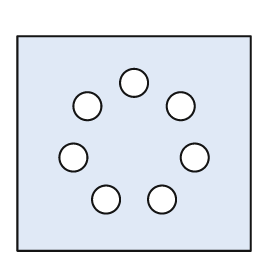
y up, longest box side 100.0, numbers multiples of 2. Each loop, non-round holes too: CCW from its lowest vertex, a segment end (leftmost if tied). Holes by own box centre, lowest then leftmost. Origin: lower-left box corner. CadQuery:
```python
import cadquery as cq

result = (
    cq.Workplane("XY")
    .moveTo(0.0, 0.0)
    .lineTo(100.0, 0.0)
    .lineTo(100.0, 92.0)
    .lineTo(0.0, 92.0)
    .close()
    .moveTo(38.0, 22.0)
    .circle(6.0)
    .moveTo(62.0, 22.0)
    .circle(6.0)
    .moveTo(24.0, 40.0)
    .circle(6.0)
    .moveTo(76.0, 40.0)
    .circle(6.0)
    .moveTo(30.0, 62.0)
    .circle(6.0)
    .moveTo(70.0, 62.0)
    .circle(6.0)
    .moveTo(50.0, 72.0)
    .circle(6.0)
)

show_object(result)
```